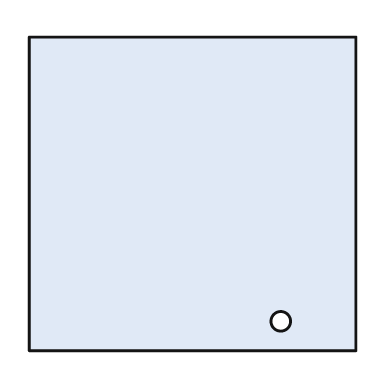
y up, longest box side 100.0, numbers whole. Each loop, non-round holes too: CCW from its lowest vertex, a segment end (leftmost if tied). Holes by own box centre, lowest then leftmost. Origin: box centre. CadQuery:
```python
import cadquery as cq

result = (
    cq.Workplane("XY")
    .moveTo(-50.0, -48.0)
    .lineTo(50.0, -48.0)
    .lineTo(50.0, 48.0)
    .lineTo(-50.0, 48.0)
    .close()
    .moveTo(27.0, -39.0)
    .circle(3.0)
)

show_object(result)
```